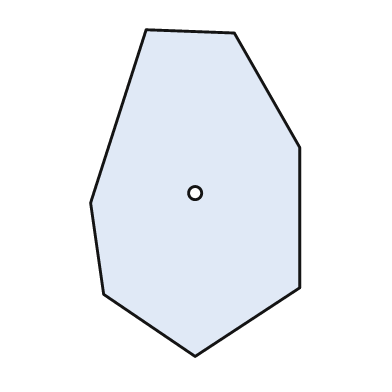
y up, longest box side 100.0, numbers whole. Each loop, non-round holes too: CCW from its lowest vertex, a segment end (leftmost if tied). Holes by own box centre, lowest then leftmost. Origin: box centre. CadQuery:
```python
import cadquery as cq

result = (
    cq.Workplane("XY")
    .moveTo(0.0, -50.0)
    .lineTo(32.0, -29.0)
    .lineTo(32.0, 14.0)
    .lineTo(12.0, 49.0)
    .lineTo(-15.0, 50.0)
    .lineTo(-32.0, -3.0)
    .lineTo(-28.0, -31.0)
    .close()
    .moveTo(0.0, 0.0)
    .circle(2.0)
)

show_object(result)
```